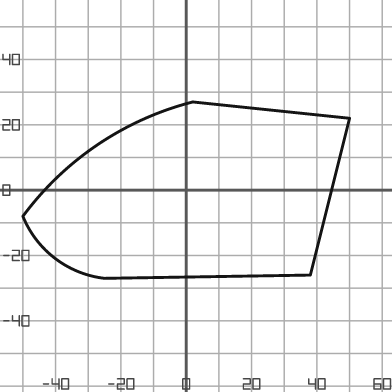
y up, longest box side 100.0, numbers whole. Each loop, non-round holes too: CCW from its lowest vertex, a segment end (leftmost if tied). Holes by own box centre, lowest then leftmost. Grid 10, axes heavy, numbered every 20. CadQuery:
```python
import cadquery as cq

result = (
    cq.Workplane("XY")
    .moveTo(-25.0, -27.0)
    .lineTo(38.0, -26.0)
    .lineTo(50.0, 22.0)
    .lineTo(2.0, 27.0)
    .threePointArc((-27.0, 14.0), (-50.0, -8.0))
    .threePointArc((-40.0, -21.0), (-25.0, -27.0))
    .close()
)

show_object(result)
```